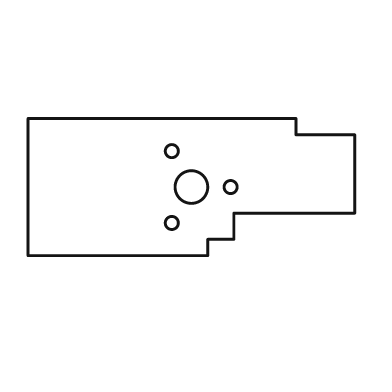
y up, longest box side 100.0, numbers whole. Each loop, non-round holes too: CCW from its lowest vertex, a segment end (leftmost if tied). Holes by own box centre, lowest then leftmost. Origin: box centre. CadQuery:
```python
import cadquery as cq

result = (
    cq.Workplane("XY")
    .moveTo(-50.0, -21.0)
    .lineTo(5.0, -21.0)
    .lineTo(5.0, -16.0)
    .lineTo(13.0, -16.0)
    .lineTo(13.0, -8.0)
    .lineTo(50.0, -8.0)
    .lineTo(50.0, 16.0)
    .lineTo(32.0, 16.0)
    .lineTo(32.0, 21.0)
    .lineTo(-50.0, 21.0)
    .close()
    .moveTo(-6.0, -11.0)
    .circle(2.0)
    .moveTo(0.0, 0.0)
    .circle(5.0)
    .moveTo(12.0, 0.0)
    .circle(2.0)
    .moveTo(-6.0, 11.0)
    .circle(2.0)
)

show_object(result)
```